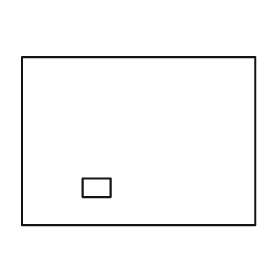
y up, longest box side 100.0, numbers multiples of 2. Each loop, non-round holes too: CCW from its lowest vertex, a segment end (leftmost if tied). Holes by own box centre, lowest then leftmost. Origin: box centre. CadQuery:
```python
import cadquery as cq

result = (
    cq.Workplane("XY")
    .moveTo(-50.0, -36.0)
    .lineTo(50.0, -36.0)
    .lineTo(50.0, 36.0)
    .lineTo(-50.0, 36.0)
    .close()
    .moveTo(-24.0, -24.0)
    .lineTo(-12.0, -24.0)
    .lineTo(-12.0, -16.0)
    .lineTo(-24.0, -16.0)
    .close()
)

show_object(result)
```